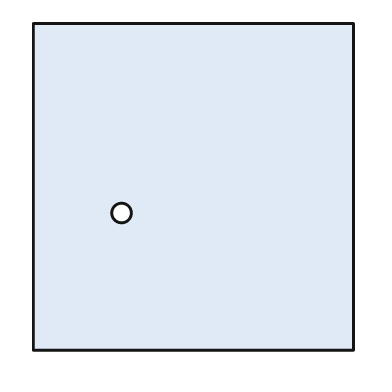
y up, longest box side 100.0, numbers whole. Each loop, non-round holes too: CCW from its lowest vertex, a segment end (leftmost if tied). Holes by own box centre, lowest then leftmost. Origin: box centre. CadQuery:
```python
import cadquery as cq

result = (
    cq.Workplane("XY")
    .moveTo(-49.0, -50.0)
    .lineTo(49.0, -50.0)
    .lineTo(49.0, 50.0)
    .lineTo(-49.0, 50.0)
    .close()
    .moveTo(-22.0, -8.0)
    .circle(3.0)
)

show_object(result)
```